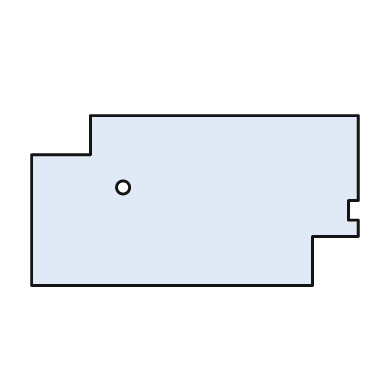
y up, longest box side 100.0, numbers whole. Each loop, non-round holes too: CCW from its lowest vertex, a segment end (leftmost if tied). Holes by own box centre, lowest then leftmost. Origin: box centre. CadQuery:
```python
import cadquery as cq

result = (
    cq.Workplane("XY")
    .moveTo(-50.0, -26.0)
    .lineTo(36.0, -26.0)
    .lineTo(36.0, -11.0)
    .lineTo(50.0, -11.0)
    .lineTo(50.0, -6.0)
    .lineTo(47.0, -6.0)
    .lineTo(47.0, 0.0)
    .lineTo(50.0, 0.0)
    .lineTo(50.0, 26.0)
    .lineTo(-32.0, 26.0)
    .lineTo(-32.0, 14.0)
    .lineTo(-50.0, 14.0)
    .close()
    .moveTo(-22.0, 4.0)
    .circle(2.0)
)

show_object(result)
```